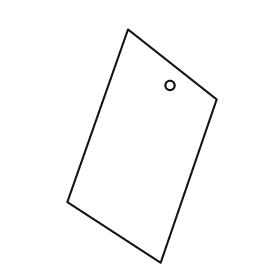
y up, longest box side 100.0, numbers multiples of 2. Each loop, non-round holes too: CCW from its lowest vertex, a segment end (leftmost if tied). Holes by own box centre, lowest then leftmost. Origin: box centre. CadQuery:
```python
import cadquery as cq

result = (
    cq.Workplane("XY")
    .moveTo(8.0, -50.0)
    .lineTo(32.0, 20.0)
    .lineTo(-6.0, 50.0)
    .lineTo(-32.0, -24.0)
    .close()
    .moveTo(12.0, 26.0)
    .circle(2.0)
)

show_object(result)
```